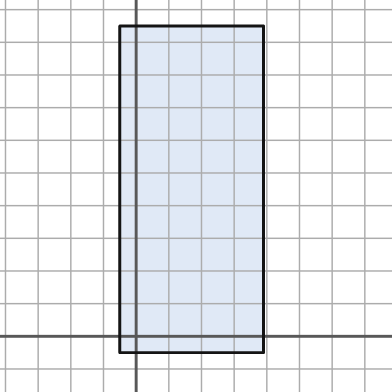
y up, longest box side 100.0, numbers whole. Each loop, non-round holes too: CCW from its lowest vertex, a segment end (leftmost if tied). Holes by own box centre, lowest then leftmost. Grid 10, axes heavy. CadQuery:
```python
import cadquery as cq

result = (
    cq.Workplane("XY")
    .moveTo(-5.0, -5.0)
    .lineTo(39.0, -5.0)
    .lineTo(39.0, 95.0)
    .lineTo(-5.0, 95.0)
    .close()
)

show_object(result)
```